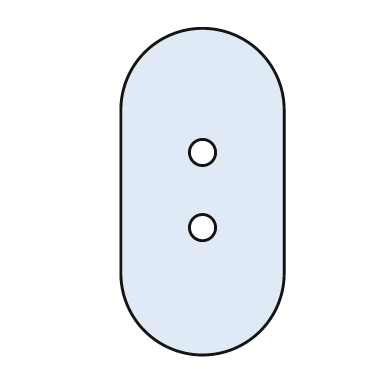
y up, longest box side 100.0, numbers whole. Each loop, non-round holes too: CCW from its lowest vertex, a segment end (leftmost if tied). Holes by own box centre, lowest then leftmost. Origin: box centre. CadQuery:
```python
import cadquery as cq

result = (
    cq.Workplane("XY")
    .moveTo(-25.0, -25.0)
    .threePointArc((0.0, -50.0), (25.0, -25.0))
    .lineTo(25.0, 25.0)
    .threePointArc((0.0, 50.0), (-25.0, 25.0))
    .close()
    .moveTo(0.0, -11.0)
    .circle(4.0)
    .moveTo(0.0, 12.0)
    .circle(4.0)
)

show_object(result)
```